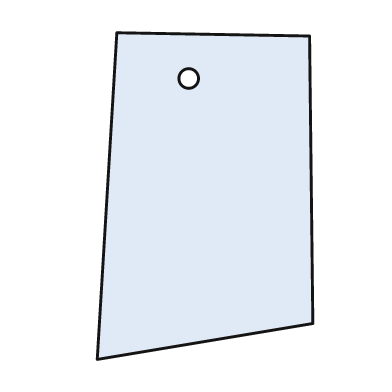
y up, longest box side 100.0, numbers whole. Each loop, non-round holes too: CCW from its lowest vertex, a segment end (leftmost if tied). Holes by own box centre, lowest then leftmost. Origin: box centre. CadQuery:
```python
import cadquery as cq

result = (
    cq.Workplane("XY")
    .moveTo(-33.0, -50.0)
    .lineTo(33.0, -39.0)
    .lineTo(32.0, 49.0)
    .lineTo(-27.0, 50.0)
    .close()
    .moveTo(-5.0, 36.0)
    .circle(3.0)
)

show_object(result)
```